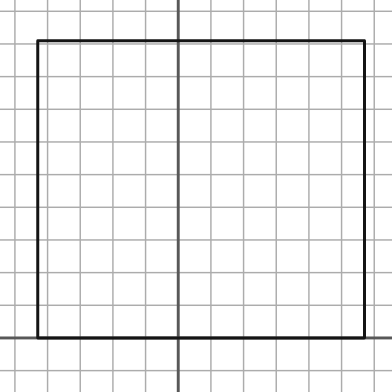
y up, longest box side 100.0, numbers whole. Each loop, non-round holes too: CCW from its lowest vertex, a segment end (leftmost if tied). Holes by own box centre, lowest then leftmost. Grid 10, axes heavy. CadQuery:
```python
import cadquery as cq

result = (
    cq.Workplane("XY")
    .moveTo(-43.0, 0.0)
    .lineTo(57.0, 0.0)
    .lineTo(57.0, 91.0)
    .lineTo(-43.0, 91.0)
    .close()
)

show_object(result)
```